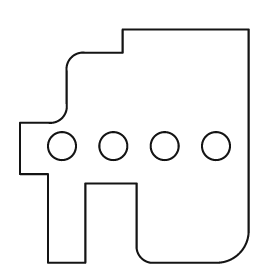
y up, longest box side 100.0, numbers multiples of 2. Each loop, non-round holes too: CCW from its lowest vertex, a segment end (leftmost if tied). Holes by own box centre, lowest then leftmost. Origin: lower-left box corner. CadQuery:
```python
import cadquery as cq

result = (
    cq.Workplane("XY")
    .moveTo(12.0, 0.0)
    .lineTo(28.0, 0.0)
    .lineTo(28.0, 34.0)
    .lineTo(50.0, 34.0)
    .lineTo(50.0, 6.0)
    .threePointArc((52.0, 2.0), (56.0, 0.0))
    .lineTo(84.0, 0.0)
    .threePointArc((94.0, 4.0), (98.0, 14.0))
    .lineTo(98.0, 100.0)
    .lineTo(44.0, 100.0)
    .lineTo(44.0, 90.0)
    .lineTo(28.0, 90.0)
    .threePointArc((22.0, 88.0), (20.0, 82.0))
    .lineTo(20.0, 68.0)
    .threePointArc((18.0, 62.0), (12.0, 60.0))
    .lineTo(0.0, 60.0)
    .lineTo(0.0, 38.0)
    .lineTo(12.0, 38.0)
    .close()
    .moveTo(18.0, 50.0)
    .circle(6.0)
    .moveTo(40.0, 50.0)
    .circle(6.0)
    .moveTo(62.0, 50.0)
    .circle(6.0)
    .moveTo(84.0, 50.0)
    .circle(6.0)
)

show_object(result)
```